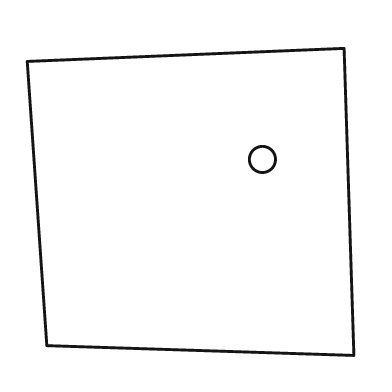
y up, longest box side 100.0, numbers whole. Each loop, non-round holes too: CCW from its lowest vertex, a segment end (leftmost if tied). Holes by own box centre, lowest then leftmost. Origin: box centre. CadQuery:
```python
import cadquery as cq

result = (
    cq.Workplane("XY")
    .moveTo(50.0, -47.0)
    .lineTo(47.0, 47.0)
    .lineTo(-50.0, 43.0)
    .lineTo(-44.0, -44.0)
    .close()
    .moveTo(22.0, 13.0)
    .circle(4.0)
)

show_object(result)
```